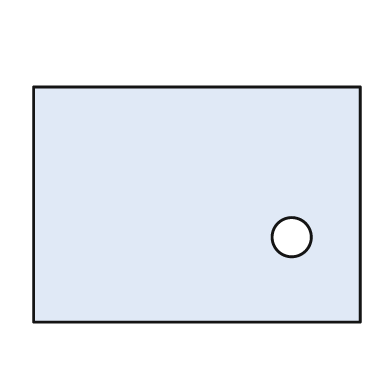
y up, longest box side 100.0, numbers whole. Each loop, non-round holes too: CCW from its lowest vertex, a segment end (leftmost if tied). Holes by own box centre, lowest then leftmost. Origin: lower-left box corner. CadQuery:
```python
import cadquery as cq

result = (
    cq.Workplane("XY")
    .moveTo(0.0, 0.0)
    .lineTo(100.0, 0.0)
    .lineTo(100.0, 72.0)
    .lineTo(0.0, 72.0)
    .close()
    .moveTo(79.0, 26.0)
    .circle(6.0)
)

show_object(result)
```